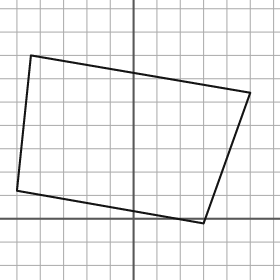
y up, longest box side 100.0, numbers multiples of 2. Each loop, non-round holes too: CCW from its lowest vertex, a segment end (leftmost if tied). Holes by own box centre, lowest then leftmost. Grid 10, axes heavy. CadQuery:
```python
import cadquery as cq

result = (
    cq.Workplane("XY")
    .moveTo(30.0, -2.0)
    .lineTo(50.0, 54.0)
    .lineTo(-44.0, 70.0)
    .lineTo(-50.0, 12.0)
    .close()
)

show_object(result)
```